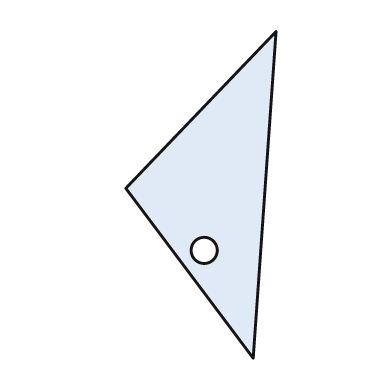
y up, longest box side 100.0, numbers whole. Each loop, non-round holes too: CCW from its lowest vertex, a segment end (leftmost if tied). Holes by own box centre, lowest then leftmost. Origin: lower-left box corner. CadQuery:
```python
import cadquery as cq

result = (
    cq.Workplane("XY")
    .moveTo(39.0, 0.0)
    .lineTo(46.0, 100.0)
    .lineTo(0.0, 52.0)
    .close()
    .moveTo(24.0, 33.0)
    .circle(4.0)
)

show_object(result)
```